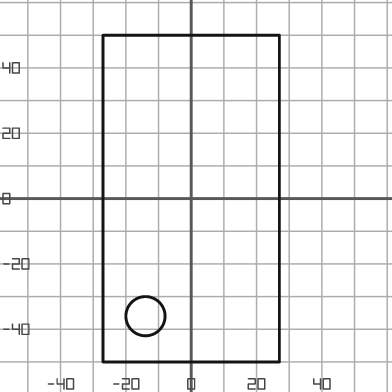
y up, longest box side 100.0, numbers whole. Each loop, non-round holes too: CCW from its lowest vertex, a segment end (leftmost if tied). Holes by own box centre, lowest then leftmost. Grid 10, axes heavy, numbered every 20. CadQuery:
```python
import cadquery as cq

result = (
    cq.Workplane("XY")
    .moveTo(-27.0, -50.0)
    .lineTo(27.0, -50.0)
    .lineTo(27.0, 50.0)
    .lineTo(-27.0, 50.0)
    .close()
    .moveTo(-14.0, -36.0)
    .circle(6.0)
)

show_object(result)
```